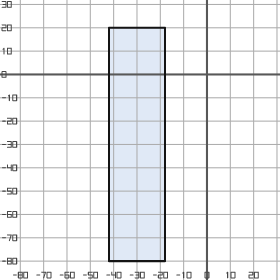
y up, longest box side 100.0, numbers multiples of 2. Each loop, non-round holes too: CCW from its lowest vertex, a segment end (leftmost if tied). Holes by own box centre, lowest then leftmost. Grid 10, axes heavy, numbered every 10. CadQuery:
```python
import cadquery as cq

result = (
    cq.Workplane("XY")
    .moveTo(-42.0, -80.0)
    .lineTo(-18.0, -80.0)
    .lineTo(-18.0, 20.0)
    .lineTo(-42.0, 20.0)
    .close()
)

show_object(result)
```